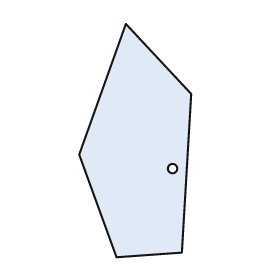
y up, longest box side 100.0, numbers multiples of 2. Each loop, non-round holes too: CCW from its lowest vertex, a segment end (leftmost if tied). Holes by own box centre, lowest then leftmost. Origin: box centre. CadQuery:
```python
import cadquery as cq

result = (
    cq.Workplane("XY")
    .moveTo(-8.0, -50.0)
    .lineTo(20.0, -48.0)
    .lineTo(24.0, 20.0)
    .lineTo(-4.0, 50.0)
    .lineTo(-24.0, -6.0)
    .close()
    .moveTo(16.0, -12.0)
    .circle(2.0)
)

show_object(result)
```